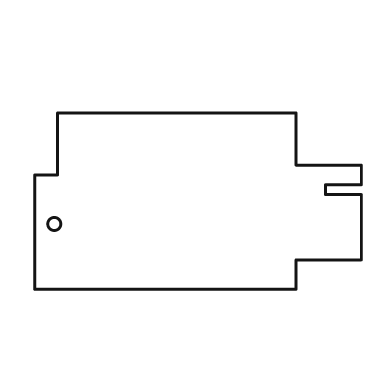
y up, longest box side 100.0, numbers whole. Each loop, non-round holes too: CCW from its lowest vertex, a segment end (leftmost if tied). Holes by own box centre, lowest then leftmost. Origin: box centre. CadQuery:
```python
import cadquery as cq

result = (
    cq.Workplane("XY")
    .moveTo(-50.0, -27.0)
    .lineTo(30.0, -27.0)
    .lineTo(30.0, -18.0)
    .lineTo(50.0, -18.0)
    .lineTo(50.0, 2.0)
    .lineTo(39.0, 2.0)
    .lineTo(39.0, 5.0)
    .lineTo(50.0, 5.0)
    .lineTo(50.0, 11.0)
    .lineTo(30.0, 11.0)
    .lineTo(30.0, 27.0)
    .lineTo(-43.0, 27.0)
    .lineTo(-43.0, 8.0)
    .lineTo(-50.0, 8.0)
    .close()
    .moveTo(-44.0, -7.0)
    .circle(2.0)
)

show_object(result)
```